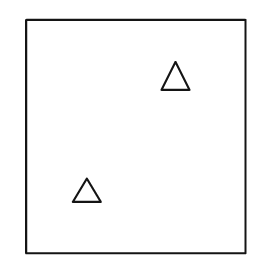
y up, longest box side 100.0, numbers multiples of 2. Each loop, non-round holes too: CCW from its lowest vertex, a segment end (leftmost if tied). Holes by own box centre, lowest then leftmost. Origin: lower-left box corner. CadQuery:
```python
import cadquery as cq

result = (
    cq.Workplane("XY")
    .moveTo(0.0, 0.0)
    .lineTo(94.0, 0.0)
    .lineTo(94.0, 100.0)
    .lineTo(0.0, 100.0)
    .close()
    .moveTo(20.0, 22.0)
    .lineTo(32.0, 22.0)
    .lineTo(26.0, 32.0)
    .close()
    .moveTo(58.0, 70.0)
    .lineTo(70.0, 70.0)
    .lineTo(64.0, 82.0)
    .close()
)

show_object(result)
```